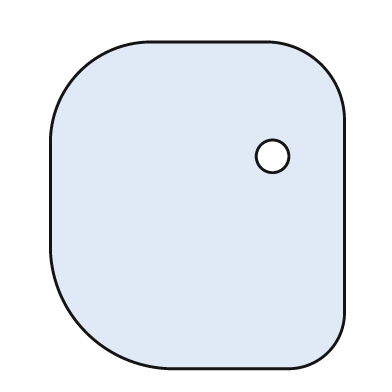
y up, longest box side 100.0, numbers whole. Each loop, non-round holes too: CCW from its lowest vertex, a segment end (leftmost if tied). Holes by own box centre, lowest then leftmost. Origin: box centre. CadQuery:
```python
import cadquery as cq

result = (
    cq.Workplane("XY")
    .moveTo(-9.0, -50.0)
    .lineTo(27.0, -50.0)
    .threePointArc((40.0, -45.0), (45.0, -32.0))
    .lineTo(45.0, 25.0)
    .threePointArc((38.0, 43.0), (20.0, 50.0))
    .lineTo(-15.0, 50.0)
    .threePointArc((-36.0, 41.0), (-45.0, 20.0))
    .lineTo(-45.0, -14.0)
    .threePointArc((-34.0, -39.0), (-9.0, -50.0))
    .close()
    .moveTo(23.0, 15.0)
    .circle(5.0)
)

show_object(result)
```